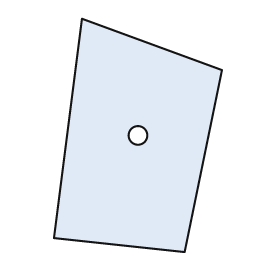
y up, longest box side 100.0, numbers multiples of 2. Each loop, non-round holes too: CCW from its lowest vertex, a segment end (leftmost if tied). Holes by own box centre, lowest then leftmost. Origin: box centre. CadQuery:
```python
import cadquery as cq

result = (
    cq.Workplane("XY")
    .moveTo(20.0, -50.0)
    .lineTo(36.0, 28.0)
    .lineTo(-24.0, 50.0)
    .lineTo(-36.0, -44.0)
    .close()
    .moveTo(0.0, 0.0)
    .circle(4.0)
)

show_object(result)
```